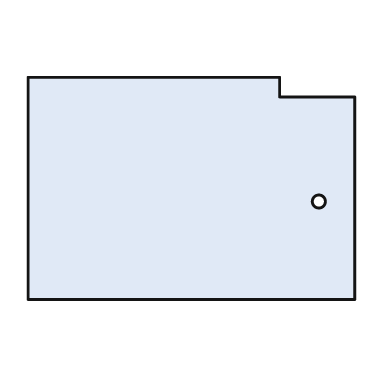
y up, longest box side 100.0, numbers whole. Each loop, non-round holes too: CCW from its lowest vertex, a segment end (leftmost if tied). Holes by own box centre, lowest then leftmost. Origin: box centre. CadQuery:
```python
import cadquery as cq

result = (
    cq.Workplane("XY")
    .moveTo(-50.0, -34.0)
    .lineTo(50.0, -34.0)
    .lineTo(50.0, 28.0)
    .lineTo(27.0, 28.0)
    .lineTo(27.0, 34.0)
    .lineTo(-50.0, 34.0)
    .close()
    .moveTo(39.0, -4.0)
    .circle(2.0)
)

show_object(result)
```